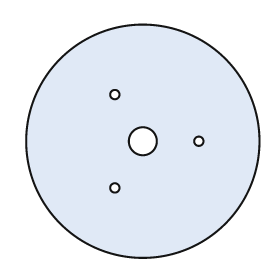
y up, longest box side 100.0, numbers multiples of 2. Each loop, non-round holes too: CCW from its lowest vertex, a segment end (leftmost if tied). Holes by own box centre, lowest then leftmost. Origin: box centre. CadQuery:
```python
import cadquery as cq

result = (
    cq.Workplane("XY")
    .moveTo(0.0, 0.0)
    .circle(50.0)
    .moveTo(-12.0, -20.0)
    .circle(2.0)
    .moveTo(0.0, 0.0)
    .circle(6.0)
    .moveTo(24.0, 0.0)
    .circle(2.0)
    .moveTo(-12.0, 20.0)
    .circle(2.0)
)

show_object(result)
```